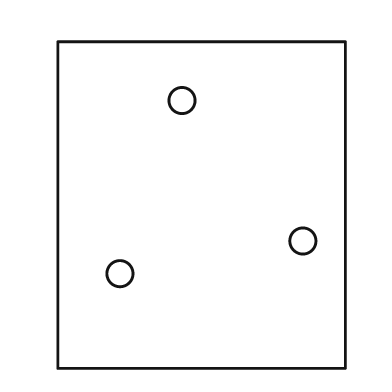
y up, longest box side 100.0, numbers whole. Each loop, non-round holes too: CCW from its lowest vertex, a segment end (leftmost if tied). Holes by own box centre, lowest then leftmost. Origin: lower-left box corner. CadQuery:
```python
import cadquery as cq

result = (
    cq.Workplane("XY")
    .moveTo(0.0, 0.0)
    .lineTo(88.0, 0.0)
    .lineTo(88.0, 100.0)
    .lineTo(0.0, 100.0)
    .close()
    .moveTo(19.0, 29.0)
    .circle(4.0)
    .moveTo(75.0, 39.0)
    .circle(4.0)
    .moveTo(38.0, 82.0)
    .circle(4.0)
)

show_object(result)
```